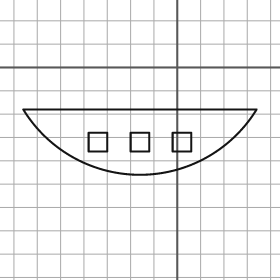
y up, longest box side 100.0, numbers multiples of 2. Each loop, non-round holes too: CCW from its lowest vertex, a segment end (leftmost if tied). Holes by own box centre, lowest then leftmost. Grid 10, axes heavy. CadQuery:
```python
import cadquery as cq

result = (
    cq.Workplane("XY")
    .moveTo(-66.0, -18.0)
    .threePointArc((-16.0, -46.0), (34.0, -18.0))
    .close()
    .moveTo(-38.0, -36.0)
    .lineTo(-30.0, -36.0)
    .lineTo(-30.0, -28.0)
    .lineTo(-38.0, -28.0)
    .close()
    .moveTo(-20.0, -36.0)
    .lineTo(-12.0, -36.0)
    .lineTo(-12.0, -28.0)
    .lineTo(-20.0, -28.0)
    .close()
    .moveTo(-2.0, -36.0)
    .lineTo(6.0, -36.0)
    .lineTo(6.0, -28.0)
    .lineTo(-2.0, -28.0)
    .close()
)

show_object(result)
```